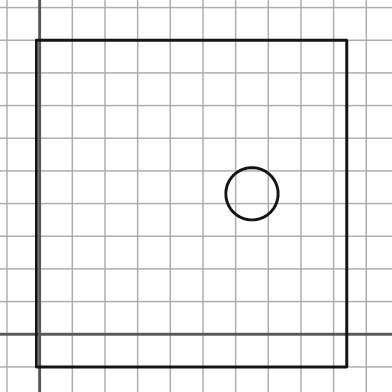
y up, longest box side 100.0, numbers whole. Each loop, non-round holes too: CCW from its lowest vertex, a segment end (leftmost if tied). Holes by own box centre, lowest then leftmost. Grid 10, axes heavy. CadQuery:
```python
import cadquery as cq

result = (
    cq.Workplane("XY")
    .moveTo(-1.0, -10.0)
    .lineTo(94.0, -10.0)
    .lineTo(94.0, 90.0)
    .lineTo(-1.0, 90.0)
    .close()
    .moveTo(65.0, 43.0)
    .circle(8.0)
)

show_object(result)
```